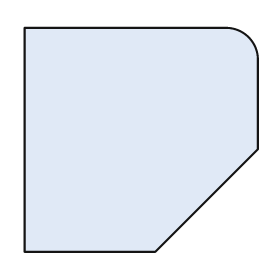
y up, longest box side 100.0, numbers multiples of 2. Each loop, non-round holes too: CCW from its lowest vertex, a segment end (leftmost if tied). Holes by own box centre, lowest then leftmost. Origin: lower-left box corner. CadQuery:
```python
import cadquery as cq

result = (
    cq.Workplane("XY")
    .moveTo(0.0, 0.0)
    .lineTo(56.0, 0.0)
    .lineTo(100.0, 44.0)
    .lineTo(100.0, 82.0)
    .threePointArc((96.0, 92.0), (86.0, 96.0))
    .lineTo(0.0, 96.0)
    .close()
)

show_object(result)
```